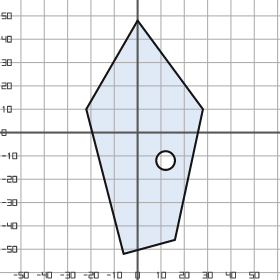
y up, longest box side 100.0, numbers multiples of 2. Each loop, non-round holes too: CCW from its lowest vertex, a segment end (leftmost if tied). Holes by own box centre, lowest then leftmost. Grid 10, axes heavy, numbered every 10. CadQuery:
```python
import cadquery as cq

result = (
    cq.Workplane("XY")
    .moveTo(-6.0, -52.0)
    .lineTo(16.0, -46.0)
    .lineTo(28.0, 10.0)
    .lineTo(0.0, 48.0)
    .lineTo(-22.0, 10.0)
    .close()
    .moveTo(12.0, -12.0)
    .circle(4.0)
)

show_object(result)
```